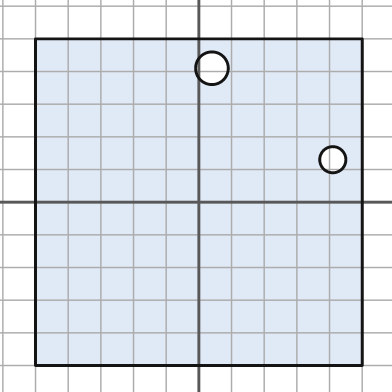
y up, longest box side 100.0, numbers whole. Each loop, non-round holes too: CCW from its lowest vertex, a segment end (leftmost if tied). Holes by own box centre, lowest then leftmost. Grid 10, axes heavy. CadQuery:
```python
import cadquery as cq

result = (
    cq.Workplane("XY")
    .moveTo(-50.0, -50.0)
    .lineTo(50.0, -50.0)
    .lineTo(50.0, 50.0)
    .lineTo(-50.0, 50.0)
    .close()
    .moveTo(41.0, 13.0)
    .circle(4.0)
    .moveTo(4.0, 41.0)
    .circle(5.0)
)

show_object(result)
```